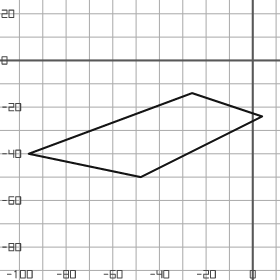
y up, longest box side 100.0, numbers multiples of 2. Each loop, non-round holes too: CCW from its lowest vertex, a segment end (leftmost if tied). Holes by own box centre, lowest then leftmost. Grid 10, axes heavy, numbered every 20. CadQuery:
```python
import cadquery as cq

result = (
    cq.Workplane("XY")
    .moveTo(-48.0, -50.0)
    .lineTo(4.0, -24.0)
    .lineTo(-26.0, -14.0)
    .lineTo(-96.0, -40.0)
    .close()
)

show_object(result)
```